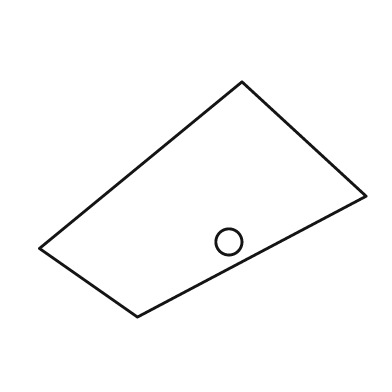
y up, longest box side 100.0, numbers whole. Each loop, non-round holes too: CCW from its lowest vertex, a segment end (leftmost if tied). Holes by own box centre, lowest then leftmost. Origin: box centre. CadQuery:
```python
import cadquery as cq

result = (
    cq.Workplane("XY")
    .moveTo(-20.0, -36.0)
    .lineTo(50.0, 1.0)
    .lineTo(12.0, 36.0)
    .lineTo(-50.0, -15.0)
    .close()
    .moveTo(8.0, -13.0)
    .circle(4.0)
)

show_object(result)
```